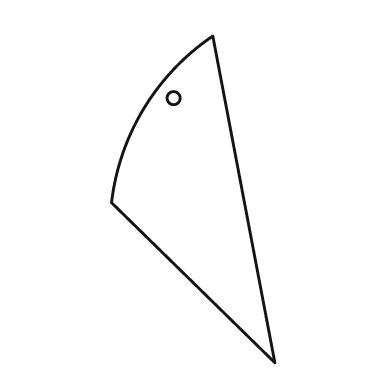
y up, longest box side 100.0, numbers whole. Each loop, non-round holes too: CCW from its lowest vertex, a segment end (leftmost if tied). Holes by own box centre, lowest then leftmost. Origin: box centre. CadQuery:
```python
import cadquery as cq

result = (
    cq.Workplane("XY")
    .moveTo(25.0, -50.0)
    .lineTo(6.0, 50.0)
    .threePointArc((-15.0, 28.0), (-25.0, -1.0))
    .close()
    .moveTo(-6.0, 31.0)
    .circle(2.0)
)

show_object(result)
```